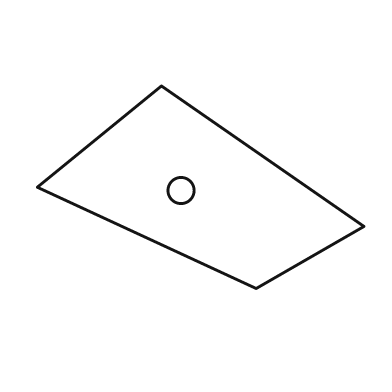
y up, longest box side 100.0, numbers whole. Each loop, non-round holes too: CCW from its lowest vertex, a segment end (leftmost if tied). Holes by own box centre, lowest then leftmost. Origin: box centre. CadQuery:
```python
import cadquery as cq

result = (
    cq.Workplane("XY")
    .moveTo(17.0, -31.0)
    .lineTo(50.0, -12.0)
    .lineTo(-12.0, 31.0)
    .lineTo(-50.0, 0.0)
    .close()
    .moveTo(-6.0, -1.0)
    .circle(4.0)
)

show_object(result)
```